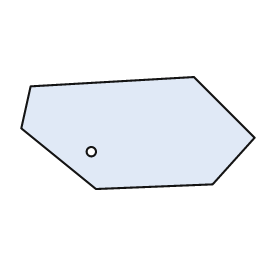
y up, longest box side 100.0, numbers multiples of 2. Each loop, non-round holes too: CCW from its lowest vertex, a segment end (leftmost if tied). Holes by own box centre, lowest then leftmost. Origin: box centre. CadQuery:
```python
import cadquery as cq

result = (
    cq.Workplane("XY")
    .moveTo(-18.0, -24.0)
    .lineTo(32.0, -22.0)
    .lineTo(50.0, -2.0)
    .lineTo(24.0, 24.0)
    .lineTo(-46.0, 20.0)
    .lineTo(-50.0, 2.0)
    .close()
    .moveTo(-20.0, -8.0)
    .circle(2.0)
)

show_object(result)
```